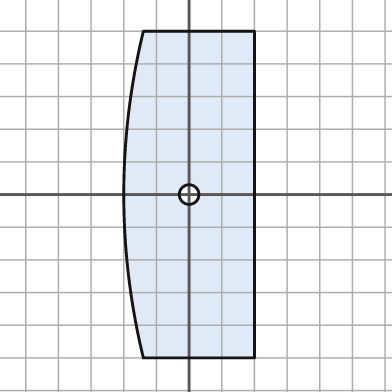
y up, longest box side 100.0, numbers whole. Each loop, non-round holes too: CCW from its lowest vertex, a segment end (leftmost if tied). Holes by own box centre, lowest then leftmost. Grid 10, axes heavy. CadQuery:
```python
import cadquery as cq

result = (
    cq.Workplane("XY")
    .moveTo(-14.0, -50.0)
    .lineTo(20.0, -50.0)
    .lineTo(20.0, 50.0)
    .lineTo(-14.0, 50.0)
    .threePointArc((-20.0, 0.0), (-14.0, -50.0))
    .close()
    .moveTo(0.0, 0.0)
    .circle(3.0)
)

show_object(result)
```